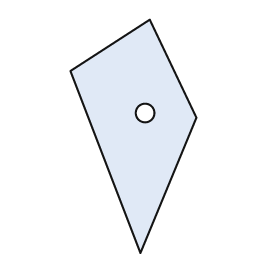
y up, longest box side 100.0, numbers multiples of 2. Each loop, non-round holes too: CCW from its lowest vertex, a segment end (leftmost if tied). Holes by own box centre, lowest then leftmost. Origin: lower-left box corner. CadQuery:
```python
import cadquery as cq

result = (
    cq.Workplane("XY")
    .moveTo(30.0, 0.0)
    .lineTo(54.0, 58.0)
    .lineTo(34.0, 100.0)
    .lineTo(0.0, 78.0)
    .close()
    .moveTo(32.0, 60.0)
    .circle(4.0)
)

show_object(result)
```